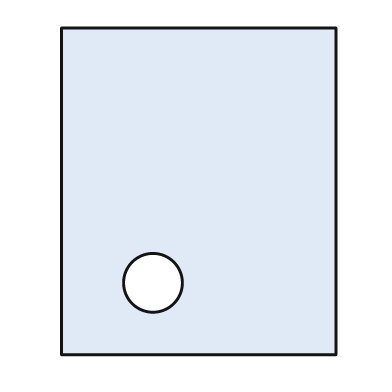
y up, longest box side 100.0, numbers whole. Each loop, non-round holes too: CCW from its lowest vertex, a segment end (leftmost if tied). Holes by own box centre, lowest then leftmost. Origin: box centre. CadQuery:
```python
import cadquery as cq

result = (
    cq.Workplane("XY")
    .moveTo(-42.0, -50.0)
    .lineTo(42.0, -50.0)
    .lineTo(42.0, 50.0)
    .lineTo(-42.0, 50.0)
    .close()
    .moveTo(-14.0, -28.0)
    .circle(9.0)
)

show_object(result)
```